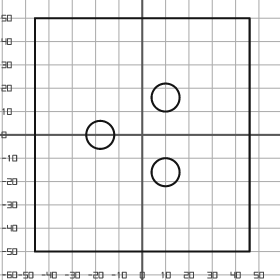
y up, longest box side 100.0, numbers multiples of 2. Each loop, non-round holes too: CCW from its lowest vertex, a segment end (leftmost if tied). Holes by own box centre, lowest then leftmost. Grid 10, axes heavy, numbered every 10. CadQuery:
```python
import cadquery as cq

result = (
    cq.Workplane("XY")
    .moveTo(-46.0, -50.0)
    .lineTo(46.0, -50.0)
    .lineTo(46.0, 50.0)
    .lineTo(-46.0, 50.0)
    .close()
    .moveTo(10.0, -16.0)
    .circle(6.0)
    .moveTo(-18.0, 0.0)
    .circle(6.0)
    .moveTo(10.0, 16.0)
    .circle(6.0)
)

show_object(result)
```